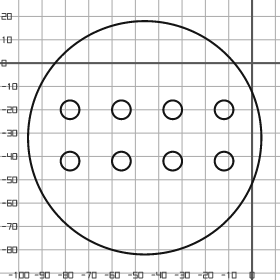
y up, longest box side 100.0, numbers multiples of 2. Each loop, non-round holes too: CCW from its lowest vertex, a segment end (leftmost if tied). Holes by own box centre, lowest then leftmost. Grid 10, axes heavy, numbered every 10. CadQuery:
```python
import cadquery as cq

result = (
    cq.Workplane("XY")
    .moveTo(-46.0, -32.0)
    .circle(50.0)
    .moveTo(-78.0, -42.0)
    .circle(4.0)
    .moveTo(-56.0, -42.0)
    .circle(4.0)
    .moveTo(-34.0, -42.0)
    .circle(4.0)
    .moveTo(-12.0, -42.0)
    .circle(4.0)
    .moveTo(-78.0, -20.0)
    .circle(4.0)
    .moveTo(-56.0, -20.0)
    .circle(4.0)
    .moveTo(-34.0, -20.0)
    .circle(4.0)
    .moveTo(-12.0, -20.0)
    .circle(4.0)
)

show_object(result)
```